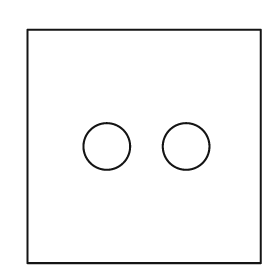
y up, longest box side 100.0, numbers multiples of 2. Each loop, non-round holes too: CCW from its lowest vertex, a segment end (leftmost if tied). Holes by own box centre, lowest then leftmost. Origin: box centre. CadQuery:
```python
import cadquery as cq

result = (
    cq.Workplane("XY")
    .moveTo(-50.0, -50.0)
    .lineTo(50.0, -50.0)
    .lineTo(50.0, 50.0)
    .lineTo(-50.0, 50.0)
    .close()
    .moveTo(-16.0, 0.0)
    .circle(10.0)
    .moveTo(18.0, 0.0)
    .circle(10.0)
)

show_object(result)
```